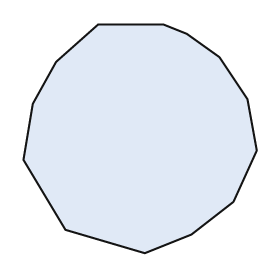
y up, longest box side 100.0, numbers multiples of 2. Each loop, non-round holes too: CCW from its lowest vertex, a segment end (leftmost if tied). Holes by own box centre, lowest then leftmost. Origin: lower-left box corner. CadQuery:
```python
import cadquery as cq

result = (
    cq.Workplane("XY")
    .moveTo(52.0, 0.0)
    .lineTo(72.0, 8.0)
    .lineTo(90.0, 22.0)
    .lineTo(100.0, 44.0)
    .lineTo(96.0, 66.0)
    .lineTo(84.0, 84.0)
    .lineTo(70.0, 94.0)
    .lineTo(60.0, 98.0)
    .lineTo(32.0, 98.0)
    .lineTo(14.0, 82.0)
    .lineTo(4.0, 64.0)
    .lineTo(0.0, 40.0)
    .lineTo(18.0, 10.0)
    .close()
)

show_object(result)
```